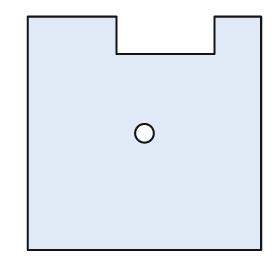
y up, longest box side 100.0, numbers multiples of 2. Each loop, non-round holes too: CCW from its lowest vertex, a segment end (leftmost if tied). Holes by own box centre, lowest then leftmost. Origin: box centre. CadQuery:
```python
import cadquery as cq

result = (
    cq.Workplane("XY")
    .moveTo(-50.0, -50.0)
    .lineTo(50.0, -50.0)
    .lineTo(50.0, 50.0)
    .lineTo(30.0, 50.0)
    .lineTo(30.0, 34.0)
    .lineTo(-12.0, 34.0)
    .lineTo(-12.0, 50.0)
    .lineTo(-50.0, 50.0)
    .close()
    .moveTo(0.0, 0.0)
    .circle(4.0)
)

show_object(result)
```